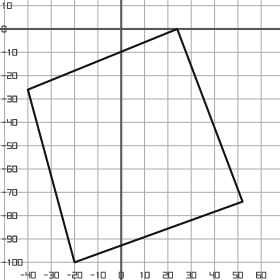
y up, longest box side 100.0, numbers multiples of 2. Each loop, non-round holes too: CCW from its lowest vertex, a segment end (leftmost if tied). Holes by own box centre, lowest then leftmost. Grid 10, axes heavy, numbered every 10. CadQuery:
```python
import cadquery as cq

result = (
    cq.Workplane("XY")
    .moveTo(-20.0, -100.0)
    .lineTo(52.0, -74.0)
    .lineTo(24.0, 0.0)
    .lineTo(-40.0, -26.0)
    .close()
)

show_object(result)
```